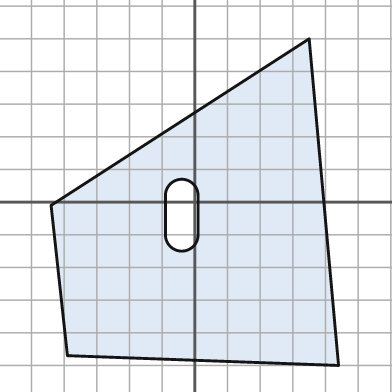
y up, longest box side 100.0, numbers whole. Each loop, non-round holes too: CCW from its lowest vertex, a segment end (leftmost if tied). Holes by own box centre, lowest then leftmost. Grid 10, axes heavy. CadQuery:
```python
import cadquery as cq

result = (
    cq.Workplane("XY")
    .moveTo(44.0, -50.0)
    .lineTo(35.0, 50.0)
    .lineTo(-44.0, -1.0)
    .lineTo(-39.0, -47.0)
    .close()
    .moveTo(-9.0, -10.0)
    .threePointArc((-4.0, -15.0), (1.0, -10.0))
    .lineTo(1.0, 2.0)
    .threePointArc((-4.0, 7.0), (-9.0, 2.0))
    .close()
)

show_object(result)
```